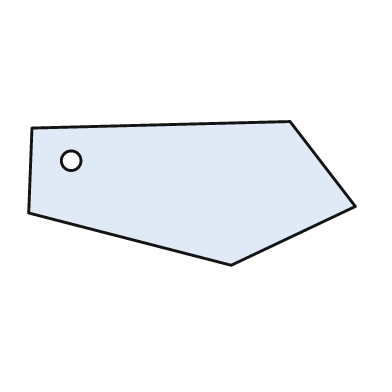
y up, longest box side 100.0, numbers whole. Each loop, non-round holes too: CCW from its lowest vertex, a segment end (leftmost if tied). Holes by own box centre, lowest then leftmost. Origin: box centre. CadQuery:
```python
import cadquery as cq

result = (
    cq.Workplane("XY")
    .moveTo(12.0, -22.0)
    .lineTo(50.0, -4.0)
    .lineTo(30.0, 22.0)
    .lineTo(-49.0, 20.0)
    .lineTo(-50.0, -6.0)
    .close()
    .moveTo(-37.0, 10.0)
    .circle(3.0)
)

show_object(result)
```